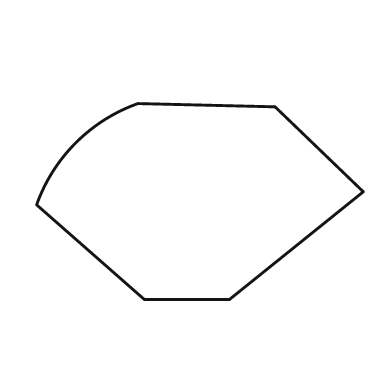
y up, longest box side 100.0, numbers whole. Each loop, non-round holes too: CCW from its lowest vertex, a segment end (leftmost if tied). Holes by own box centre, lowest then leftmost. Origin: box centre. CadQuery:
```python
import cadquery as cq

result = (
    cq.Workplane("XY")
    .moveTo(-17.0, -30.0)
    .lineTo(9.0, -30.0)
    .lineTo(50.0, 3.0)
    .lineTo(23.0, 29.0)
    .lineTo(-19.0, 30.0)
    .threePointArc((-38.0, 18.0), (-50.0, -1.0))
    .close()
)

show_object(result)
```